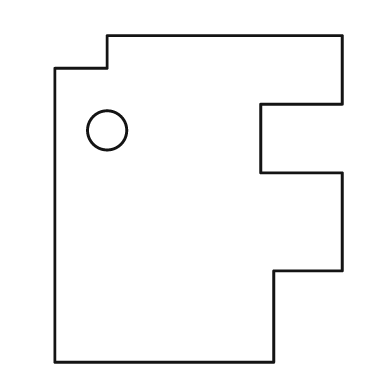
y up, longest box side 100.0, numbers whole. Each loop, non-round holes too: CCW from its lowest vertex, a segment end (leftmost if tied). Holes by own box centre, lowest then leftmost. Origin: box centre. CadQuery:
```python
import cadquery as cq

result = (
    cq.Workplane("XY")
    .moveTo(-44.0, -50.0)
    .lineTo(23.0, -50.0)
    .lineTo(23.0, -22.0)
    .lineTo(44.0, -22.0)
    .lineTo(44.0, 8.0)
    .lineTo(19.0, 8.0)
    .lineTo(19.0, 29.0)
    .lineTo(44.0, 29.0)
    .lineTo(44.0, 50.0)
    .lineTo(-28.0, 50.0)
    .lineTo(-28.0, 40.0)
    .lineTo(-44.0, 40.0)
    .close()
    .moveTo(-28.0, 21.0)
    .circle(6.0)
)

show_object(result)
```